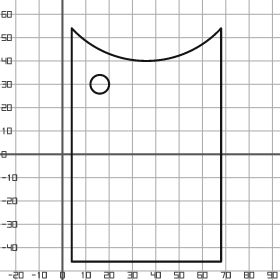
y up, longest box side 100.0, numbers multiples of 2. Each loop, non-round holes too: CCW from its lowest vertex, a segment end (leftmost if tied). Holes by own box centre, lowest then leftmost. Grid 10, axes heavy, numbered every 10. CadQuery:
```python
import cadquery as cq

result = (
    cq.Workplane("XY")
    .moveTo(4.0, -46.0)
    .lineTo(68.0, -46.0)
    .lineTo(68.0, 54.0)
    .threePointArc((36.0, 40.0), (4.0, 54.0))
    .close()
    .moveTo(16.0, 30.0)
    .circle(4.0)
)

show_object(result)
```